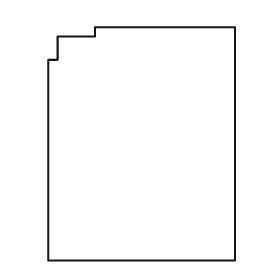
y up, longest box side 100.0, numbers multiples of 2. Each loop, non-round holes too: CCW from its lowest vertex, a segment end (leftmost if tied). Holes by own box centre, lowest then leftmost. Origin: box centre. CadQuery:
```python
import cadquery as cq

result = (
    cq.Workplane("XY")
    .moveTo(-40.0, -50.0)
    .lineTo(40.0, -50.0)
    .lineTo(40.0, 50.0)
    .lineTo(-20.0, 50.0)
    .lineTo(-20.0, 46.0)
    .lineTo(-36.0, 46.0)
    .lineTo(-36.0, 36.0)
    .lineTo(-40.0, 36.0)
    .close()
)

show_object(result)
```